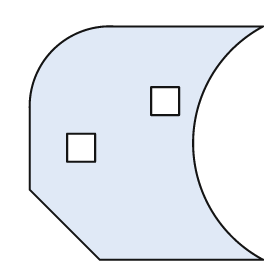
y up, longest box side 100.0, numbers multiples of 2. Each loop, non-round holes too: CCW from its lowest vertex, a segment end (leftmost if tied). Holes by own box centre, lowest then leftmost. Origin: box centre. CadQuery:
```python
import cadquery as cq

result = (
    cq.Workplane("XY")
    .moveTo(-20.0, -50.0)
    .lineTo(50.0, -50.0)
    .threePointArc((20.0, 0.0), (50.0, 50.0))
    .lineTo(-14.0, 50.0)
    .threePointArc((-40.0, 40.0), (-50.0, 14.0))
    .lineTo(-50.0, -20.0)
    .close()
    .moveTo(-34.0, -8.0)
    .lineTo(-22.0, -8.0)
    .lineTo(-22.0, 4.0)
    .lineTo(-34.0, 4.0)
    .close()
    .moveTo(2.0, 12.0)
    .lineTo(14.0, 12.0)
    .lineTo(14.0, 24.0)
    .lineTo(2.0, 24.0)
    .close()
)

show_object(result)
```